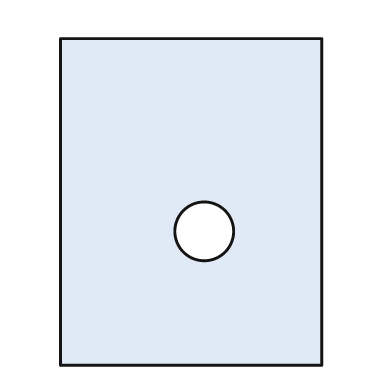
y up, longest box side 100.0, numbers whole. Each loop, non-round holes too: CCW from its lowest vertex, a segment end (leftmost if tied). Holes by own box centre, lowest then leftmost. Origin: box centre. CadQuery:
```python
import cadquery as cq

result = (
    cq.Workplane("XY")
    .moveTo(-40.0, -50.0)
    .lineTo(40.0, -50.0)
    .lineTo(40.0, 50.0)
    .lineTo(-40.0, 50.0)
    .close()
    .moveTo(4.0, -9.0)
    .circle(9.0)
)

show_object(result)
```